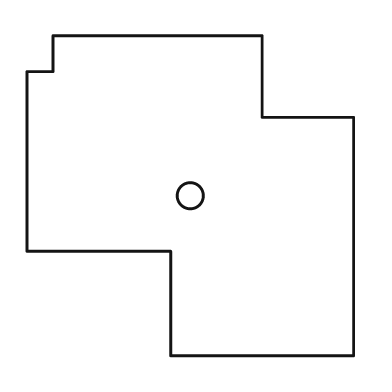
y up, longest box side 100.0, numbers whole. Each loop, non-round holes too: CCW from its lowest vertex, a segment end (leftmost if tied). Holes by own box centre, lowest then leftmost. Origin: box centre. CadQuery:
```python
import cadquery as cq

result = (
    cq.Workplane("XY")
    .moveTo(-6.0, -49.0)
    .lineTo(50.0, -49.0)
    .lineTo(50.0, 24.0)
    .lineTo(22.0, 24.0)
    .lineTo(22.0, 49.0)
    .lineTo(-42.0, 49.0)
    .lineTo(-42.0, 38.0)
    .lineTo(-50.0, 38.0)
    .lineTo(-50.0, -17.0)
    .lineTo(-6.0, -17.0)
    .close()
    .moveTo(0.0, 0.0)
    .circle(4.0)
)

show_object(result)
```